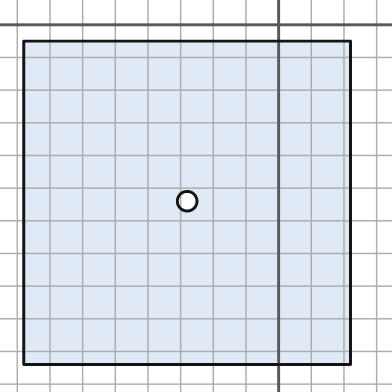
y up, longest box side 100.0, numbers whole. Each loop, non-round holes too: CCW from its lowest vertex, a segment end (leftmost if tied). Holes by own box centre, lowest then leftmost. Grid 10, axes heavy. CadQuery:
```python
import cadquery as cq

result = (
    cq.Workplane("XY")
    .moveTo(-78.0, -104.0)
    .lineTo(22.0, -104.0)
    .lineTo(22.0, -5.0)
    .lineTo(-78.0, -5.0)
    .close()
    .moveTo(-28.0, -54.0)
    .circle(3.0)
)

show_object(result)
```